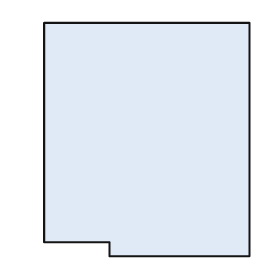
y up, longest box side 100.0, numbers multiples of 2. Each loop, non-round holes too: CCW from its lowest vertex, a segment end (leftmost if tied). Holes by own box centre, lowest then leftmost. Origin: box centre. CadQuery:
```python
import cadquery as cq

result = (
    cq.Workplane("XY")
    .moveTo(-16.0, -50.0)
    .lineTo(44.0, -50.0)
    .lineTo(44.0, 50.0)
    .lineTo(-44.0, 50.0)
    .lineTo(-44.0, -44.0)
    .lineTo(-16.0, -44.0)
    .close()
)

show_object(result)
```